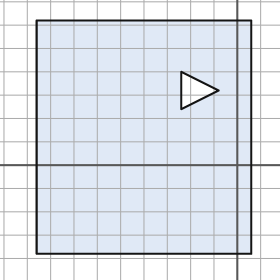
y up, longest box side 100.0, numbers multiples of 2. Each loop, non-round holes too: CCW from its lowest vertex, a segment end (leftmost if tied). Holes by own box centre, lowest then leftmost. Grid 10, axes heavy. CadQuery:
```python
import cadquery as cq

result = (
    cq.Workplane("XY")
    .moveTo(-86.0, -38.0)
    .lineTo(6.0, -38.0)
    .lineTo(6.0, 62.0)
    .lineTo(-86.0, 62.0)
    .close()
    .moveTo(-24.0, 24.0)
    .lineTo(-8.0, 32.0)
    .lineTo(-24.0, 40.0)
    .close()
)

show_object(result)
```